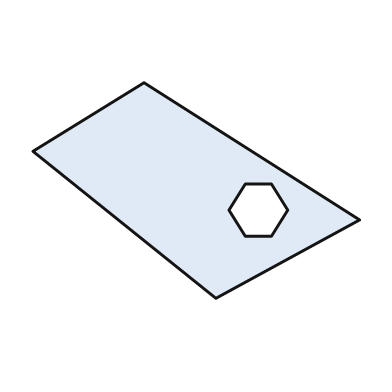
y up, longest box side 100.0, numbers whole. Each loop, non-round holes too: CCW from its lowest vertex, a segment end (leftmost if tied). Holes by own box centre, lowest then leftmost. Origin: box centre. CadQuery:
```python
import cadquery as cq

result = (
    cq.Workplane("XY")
    .moveTo(6.0, -33.0)
    .lineTo(50.0, -9.0)
    .lineTo(-16.0, 33.0)
    .lineTo(-50.0, 12.0)
    .close()
    .moveTo(15.0, -14.0)
    .lineTo(23.0, -14.0)
    .lineTo(28.0, -6.0)
    .lineTo(23.0, 2.0)
    .lineTo(15.0, 2.0)
    .lineTo(10.0, -6.0)
    .close()
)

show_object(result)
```